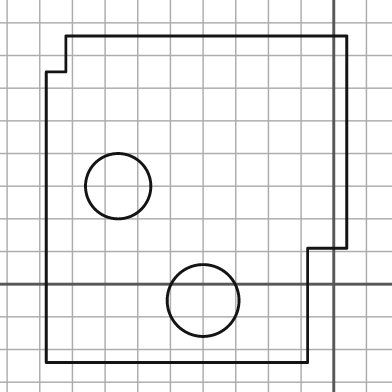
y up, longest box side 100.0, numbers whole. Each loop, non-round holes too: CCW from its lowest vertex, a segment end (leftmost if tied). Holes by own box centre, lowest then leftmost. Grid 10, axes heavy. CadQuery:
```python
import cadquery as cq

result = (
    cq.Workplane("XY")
    .moveTo(-88.0, -24.0)
    .lineTo(-8.0, -24.0)
    .lineTo(-8.0, 11.0)
    .lineTo(4.0, 11.0)
    .lineTo(4.0, 76.0)
    .lineTo(-82.0, 76.0)
    .lineTo(-82.0, 65.0)
    .lineTo(-88.0, 65.0)
    .close()
    .moveTo(-40.0, -5.0)
    .circle(11.0)
    .moveTo(-66.0, 30.0)
    .circle(10.0)
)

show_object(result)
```